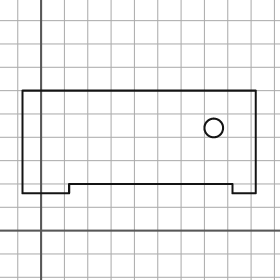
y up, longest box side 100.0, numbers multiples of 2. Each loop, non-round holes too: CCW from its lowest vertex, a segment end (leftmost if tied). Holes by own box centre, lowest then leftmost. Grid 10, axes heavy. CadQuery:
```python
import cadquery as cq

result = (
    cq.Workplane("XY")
    .moveTo(-8.0, 16.0)
    .lineTo(12.0, 16.0)
    .lineTo(12.0, 20.0)
    .lineTo(82.0, 20.0)
    .lineTo(82.0, 16.0)
    .lineTo(92.0, 16.0)
    .lineTo(92.0, 60.0)
    .lineTo(-8.0, 60.0)
    .close()
    .moveTo(74.0, 44.0)
    .circle(4.0)
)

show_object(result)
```